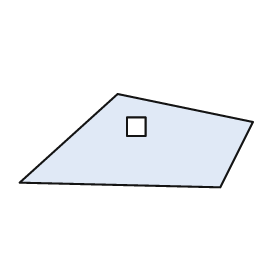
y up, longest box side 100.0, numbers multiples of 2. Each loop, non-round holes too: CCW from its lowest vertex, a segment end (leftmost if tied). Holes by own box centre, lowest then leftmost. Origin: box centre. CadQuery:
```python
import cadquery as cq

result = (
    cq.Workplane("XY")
    .moveTo(36.0, -20.0)
    .lineTo(50.0, 8.0)
    .lineTo(-8.0, 20.0)
    .lineTo(-50.0, -18.0)
    .close()
    .moveTo(-4.0, 2.0)
    .lineTo(4.0, 2.0)
    .lineTo(4.0, 10.0)
    .lineTo(-4.0, 10.0)
    .close()
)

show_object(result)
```